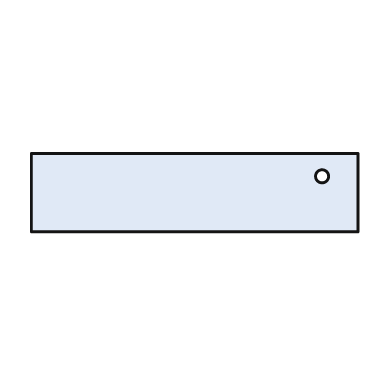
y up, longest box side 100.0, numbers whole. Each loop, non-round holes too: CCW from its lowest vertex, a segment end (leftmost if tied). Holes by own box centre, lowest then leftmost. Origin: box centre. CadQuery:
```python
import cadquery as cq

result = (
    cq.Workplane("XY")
    .moveTo(-50.0, -12.0)
    .lineTo(50.0, -12.0)
    .lineTo(50.0, 12.0)
    .lineTo(-50.0, 12.0)
    .close()
    .moveTo(39.0, 5.0)
    .circle(2.0)
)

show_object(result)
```